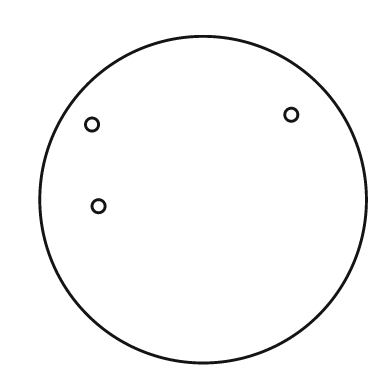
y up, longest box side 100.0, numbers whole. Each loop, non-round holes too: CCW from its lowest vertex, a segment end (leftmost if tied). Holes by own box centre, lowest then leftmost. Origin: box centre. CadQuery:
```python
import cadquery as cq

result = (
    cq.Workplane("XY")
    .moveTo(0.0, 0.0)
    .circle(50.0)
    .moveTo(-32.0, -2.0)
    .circle(2.0)
    .moveTo(-34.0, 23.0)
    .circle(2.0)
    .moveTo(27.0, 26.0)
    .circle(2.0)
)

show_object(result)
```